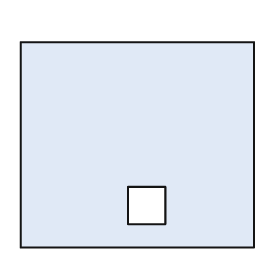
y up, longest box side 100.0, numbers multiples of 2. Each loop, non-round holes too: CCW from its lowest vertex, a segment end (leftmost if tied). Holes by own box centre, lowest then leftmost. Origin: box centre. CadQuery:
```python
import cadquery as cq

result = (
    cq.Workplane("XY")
    .moveTo(-50.0, -44.0)
    .lineTo(50.0, -44.0)
    .lineTo(50.0, 44.0)
    .lineTo(-50.0, 44.0)
    .close()
    .moveTo(-4.0, -34.0)
    .lineTo(12.0, -34.0)
    .lineTo(12.0, -18.0)
    .lineTo(-4.0, -18.0)
    .close()
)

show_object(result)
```